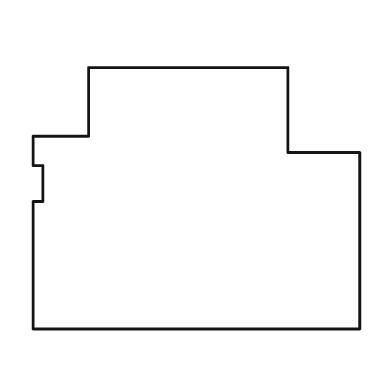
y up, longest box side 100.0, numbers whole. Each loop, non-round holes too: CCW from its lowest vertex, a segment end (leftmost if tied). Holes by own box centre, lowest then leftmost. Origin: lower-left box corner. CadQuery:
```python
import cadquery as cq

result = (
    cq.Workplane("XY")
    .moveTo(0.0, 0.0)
    .lineTo(100.0, 0.0)
    .lineTo(100.0, 54.0)
    .lineTo(78.0, 54.0)
    .lineTo(78.0, 80.0)
    .lineTo(17.0, 80.0)
    .lineTo(17.0, 59.0)
    .lineTo(0.0, 59.0)
    .lineTo(0.0, 50.0)
    .lineTo(3.0, 50.0)
    .lineTo(3.0, 39.0)
    .lineTo(0.0, 39.0)
    .close()
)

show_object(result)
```